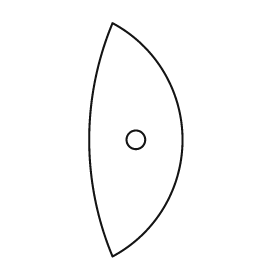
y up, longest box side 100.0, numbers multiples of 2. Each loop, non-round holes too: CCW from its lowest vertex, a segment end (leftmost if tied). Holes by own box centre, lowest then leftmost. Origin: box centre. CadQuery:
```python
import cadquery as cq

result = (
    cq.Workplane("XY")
    .moveTo(-10.0, -50.0)
    .threePointArc((20.0, 0.0), (-10.0, 50.0))
    .threePointArc((-20.0, 0.0), (-10.0, -50.0))
    .close()
    .moveTo(0.0, 0.0)
    .circle(4.0)
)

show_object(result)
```